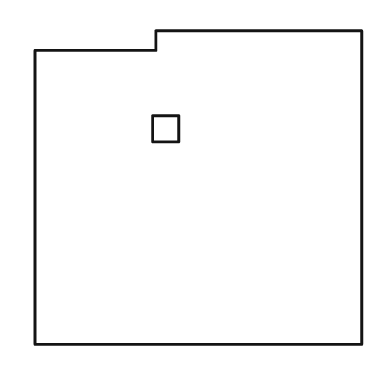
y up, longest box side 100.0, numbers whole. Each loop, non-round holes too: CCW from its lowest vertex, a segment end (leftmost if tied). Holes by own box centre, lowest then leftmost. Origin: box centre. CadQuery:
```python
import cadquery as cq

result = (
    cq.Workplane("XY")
    .moveTo(-50.0, -48.0)
    .lineTo(50.0, -48.0)
    .lineTo(50.0, 48.0)
    .lineTo(-13.0, 48.0)
    .lineTo(-13.0, 42.0)
    .lineTo(-50.0, 42.0)
    .close()
    .moveTo(-14.0, 14.0)
    .lineTo(-6.0, 14.0)
    .lineTo(-6.0, 22.0)
    .lineTo(-14.0, 22.0)
    .close()
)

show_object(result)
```